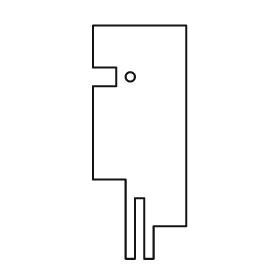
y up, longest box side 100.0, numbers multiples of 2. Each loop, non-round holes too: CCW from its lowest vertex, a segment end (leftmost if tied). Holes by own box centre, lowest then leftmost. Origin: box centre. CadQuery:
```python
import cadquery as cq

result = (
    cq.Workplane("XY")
    .moveTo(-6.0, -50.0)
    .lineTo(-2.0, -50.0)
    .lineTo(-2.0, -24.0)
    .lineTo(2.0, -24.0)
    .lineTo(2.0, -50.0)
    .lineTo(6.0, -50.0)
    .lineTo(6.0, -36.0)
    .lineTo(20.0, -36.0)
    .lineTo(20.0, 50.0)
    .lineTo(-20.0, 50.0)
    .lineTo(-20.0, 32.0)
    .lineTo(-10.0, 32.0)
    .lineTo(-10.0, 24.0)
    .lineTo(-20.0, 24.0)
    .lineTo(-20.0, -16.0)
    .lineTo(-6.0, -16.0)
    .close()
    .moveTo(-4.0, 28.0)
    .circle(2.0)
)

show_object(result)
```